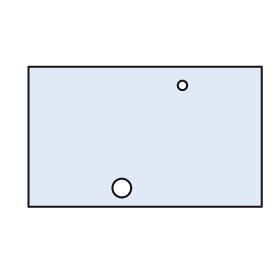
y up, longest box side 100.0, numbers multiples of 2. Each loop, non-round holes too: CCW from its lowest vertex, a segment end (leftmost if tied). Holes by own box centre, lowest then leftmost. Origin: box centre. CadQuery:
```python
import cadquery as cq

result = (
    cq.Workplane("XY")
    .moveTo(-50.0, -30.0)
    .lineTo(50.0, -30.0)
    .lineTo(50.0, 30.0)
    .lineTo(-50.0, 30.0)
    .close()
    .moveTo(-10.0, -22.0)
    .circle(4.0)
    .moveTo(16.0, 22.0)
    .circle(2.0)
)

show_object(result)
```